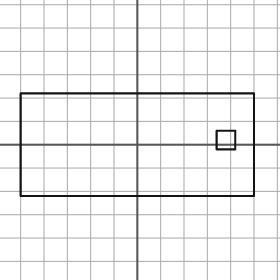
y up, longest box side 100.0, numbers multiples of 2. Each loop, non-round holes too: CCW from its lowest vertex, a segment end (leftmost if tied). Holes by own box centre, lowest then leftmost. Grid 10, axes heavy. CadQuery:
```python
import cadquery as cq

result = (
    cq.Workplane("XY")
    .moveTo(-50.0, -22.0)
    .lineTo(50.0, -22.0)
    .lineTo(50.0, 22.0)
    .lineTo(-50.0, 22.0)
    .close()
    .moveTo(34.0, -2.0)
    .lineTo(42.0, -2.0)
    .lineTo(42.0, 6.0)
    .lineTo(34.0, 6.0)
    .close()
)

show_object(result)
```